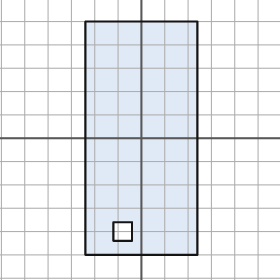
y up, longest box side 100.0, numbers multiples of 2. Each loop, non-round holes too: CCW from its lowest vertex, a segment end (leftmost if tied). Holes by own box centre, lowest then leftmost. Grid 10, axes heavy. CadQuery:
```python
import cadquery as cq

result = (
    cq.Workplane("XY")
    .moveTo(-24.0, -50.0)
    .lineTo(24.0, -50.0)
    .lineTo(24.0, 50.0)
    .lineTo(-24.0, 50.0)
    .close()
    .moveTo(-12.0, -44.0)
    .lineTo(-4.0, -44.0)
    .lineTo(-4.0, -36.0)
    .lineTo(-12.0, -36.0)
    .close()
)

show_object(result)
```